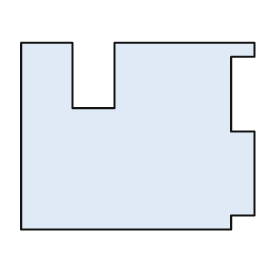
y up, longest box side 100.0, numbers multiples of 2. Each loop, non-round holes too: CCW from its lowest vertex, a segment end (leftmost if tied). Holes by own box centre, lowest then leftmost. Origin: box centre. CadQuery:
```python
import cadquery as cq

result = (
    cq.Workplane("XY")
    .moveTo(-50.0, -40.0)
    .lineTo(40.0, -40.0)
    .lineTo(40.0, -34.0)
    .lineTo(50.0, -34.0)
    .lineTo(50.0, 2.0)
    .lineTo(40.0, 2.0)
    .lineTo(40.0, 34.0)
    .lineTo(50.0, 34.0)
    .lineTo(50.0, 40.0)
    .lineTo(-10.0, 40.0)
    .lineTo(-10.0, 12.0)
    .lineTo(-28.0, 12.0)
    .lineTo(-28.0, 40.0)
    .lineTo(-50.0, 40.0)
    .close()
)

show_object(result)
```